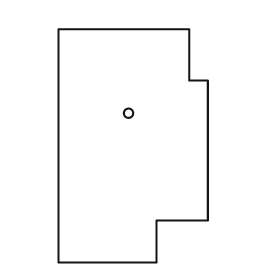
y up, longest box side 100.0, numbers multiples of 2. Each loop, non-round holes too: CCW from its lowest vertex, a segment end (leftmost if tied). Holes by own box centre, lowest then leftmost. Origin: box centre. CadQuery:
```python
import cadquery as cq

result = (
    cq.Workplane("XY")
    .moveTo(-32.0, -50.0)
    .lineTo(10.0, -50.0)
    .lineTo(10.0, -32.0)
    .lineTo(32.0, -32.0)
    .lineTo(32.0, 28.0)
    .lineTo(24.0, 28.0)
    .lineTo(24.0, 50.0)
    .lineTo(-32.0, 50.0)
    .close()
    .moveTo(-2.0, 14.0)
    .circle(2.0)
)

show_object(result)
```